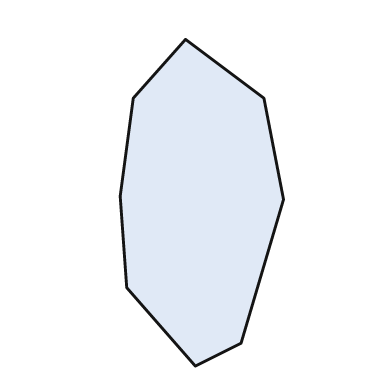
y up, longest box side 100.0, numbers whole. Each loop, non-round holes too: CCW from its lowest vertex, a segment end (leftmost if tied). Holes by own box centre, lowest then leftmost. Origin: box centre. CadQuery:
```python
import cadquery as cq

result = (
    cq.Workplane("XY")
    .moveTo(-2.0, -50.0)
    .lineTo(12.0, -43.0)
    .lineTo(25.0, 1.0)
    .lineTo(19.0, 32.0)
    .lineTo(-5.0, 50.0)
    .lineTo(-21.0, 32.0)
    .lineTo(-25.0, 2.0)
    .lineTo(-23.0, -26.0)
    .close()
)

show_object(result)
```